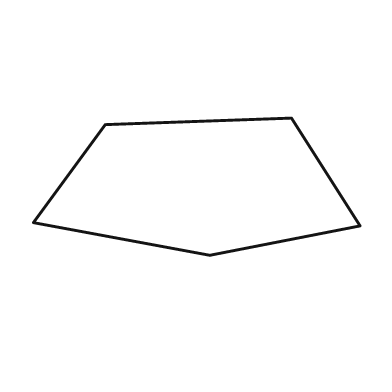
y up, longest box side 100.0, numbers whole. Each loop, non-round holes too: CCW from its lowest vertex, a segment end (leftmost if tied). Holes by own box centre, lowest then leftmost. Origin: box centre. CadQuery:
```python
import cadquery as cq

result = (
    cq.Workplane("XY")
    .moveTo(4.0, -21.0)
    .lineTo(50.0, -12.0)
    .lineTo(29.0, 21.0)
    .lineTo(-28.0, 19.0)
    .lineTo(-50.0, -11.0)
    .close()
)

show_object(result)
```